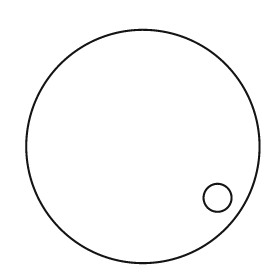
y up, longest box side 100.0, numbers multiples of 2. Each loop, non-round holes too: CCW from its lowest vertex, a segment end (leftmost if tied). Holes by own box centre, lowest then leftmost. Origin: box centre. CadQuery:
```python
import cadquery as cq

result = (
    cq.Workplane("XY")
    .moveTo(0.0, 0.0)
    .circle(50.0)
    .moveTo(32.0, -22.0)
    .circle(6.0)
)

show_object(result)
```